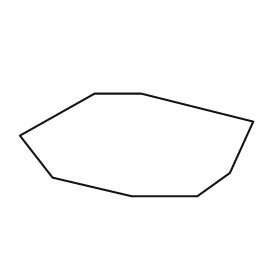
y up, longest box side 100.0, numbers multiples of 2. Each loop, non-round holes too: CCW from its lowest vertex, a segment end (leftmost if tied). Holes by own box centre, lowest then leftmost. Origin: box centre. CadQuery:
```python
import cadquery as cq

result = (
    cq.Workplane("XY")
    .moveTo(-2.0, -22.0)
    .lineTo(26.0, -22.0)
    .lineTo(40.0, -12.0)
    .lineTo(50.0, 10.0)
    .lineTo(2.0, 22.0)
    .lineTo(-18.0, 22.0)
    .lineTo(-50.0, 4.0)
    .lineTo(-36.0, -14.0)
    .close()
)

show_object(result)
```